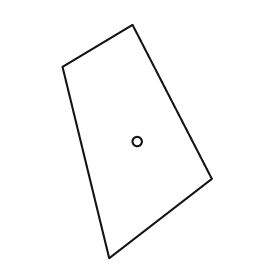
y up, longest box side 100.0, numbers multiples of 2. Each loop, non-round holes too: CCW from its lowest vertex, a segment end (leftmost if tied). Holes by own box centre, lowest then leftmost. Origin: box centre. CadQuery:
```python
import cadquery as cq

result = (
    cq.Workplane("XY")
    .moveTo(-12.0, -50.0)
    .lineTo(32.0, -16.0)
    .lineTo(-2.0, 50.0)
    .lineTo(-32.0, 32.0)
    .close()
    .moveTo(0.0, 0.0)
    .circle(2.0)
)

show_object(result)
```